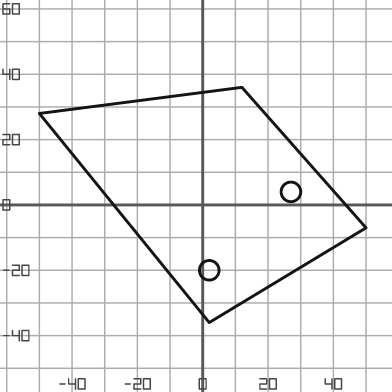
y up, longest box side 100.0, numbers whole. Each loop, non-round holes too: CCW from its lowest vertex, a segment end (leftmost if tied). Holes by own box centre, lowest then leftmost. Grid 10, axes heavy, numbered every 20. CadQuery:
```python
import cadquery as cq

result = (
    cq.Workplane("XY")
    .moveTo(2.0, -36.0)
    .lineTo(50.0, -7.0)
    .lineTo(12.0, 36.0)
    .lineTo(-50.0, 28.0)
    .close()
    .moveTo(2.0, -20.0)
    .circle(3.0)
    .moveTo(27.0, 4.0)
    .circle(3.0)
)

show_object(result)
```